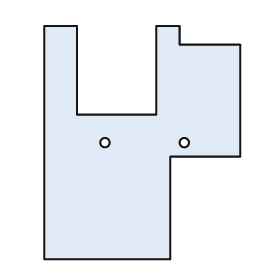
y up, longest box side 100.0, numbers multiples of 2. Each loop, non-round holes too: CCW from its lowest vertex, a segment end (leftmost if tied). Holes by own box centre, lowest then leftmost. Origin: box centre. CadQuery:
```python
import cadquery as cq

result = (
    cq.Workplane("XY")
    .moveTo(-42.0, -50.0)
    .lineTo(12.0, -50.0)
    .lineTo(12.0, -6.0)
    .lineTo(42.0, -6.0)
    .lineTo(42.0, 42.0)
    .lineTo(16.0, 42.0)
    .lineTo(16.0, 50.0)
    .lineTo(6.0, 50.0)
    .lineTo(6.0, 12.0)
    .lineTo(-28.0, 12.0)
    .lineTo(-28.0, 50.0)
    .lineTo(-42.0, 50.0)
    .close()
    .moveTo(-16.0, 0.0)
    .circle(2.0)
    .moveTo(18.0, 0.0)
    .circle(2.0)
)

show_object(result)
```